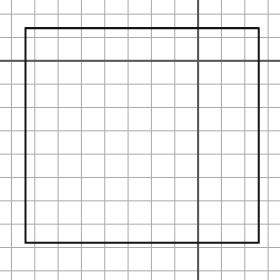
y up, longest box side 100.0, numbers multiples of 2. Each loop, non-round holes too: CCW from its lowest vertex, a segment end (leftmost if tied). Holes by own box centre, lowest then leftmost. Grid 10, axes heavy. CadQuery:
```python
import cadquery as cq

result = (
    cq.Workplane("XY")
    .moveTo(-74.0, -78.0)
    .lineTo(26.0, -78.0)
    .lineTo(26.0, 14.0)
    .lineTo(-74.0, 14.0)
    .close()
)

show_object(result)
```